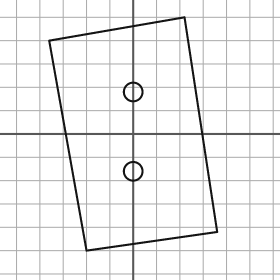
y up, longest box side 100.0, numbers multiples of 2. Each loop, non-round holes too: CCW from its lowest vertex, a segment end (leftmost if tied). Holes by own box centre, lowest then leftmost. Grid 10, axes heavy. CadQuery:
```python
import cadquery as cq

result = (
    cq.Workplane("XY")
    .moveTo(-20.0, -50.0)
    .lineTo(36.0, -42.0)
    .lineTo(22.0, 50.0)
    .lineTo(-36.0, 40.0)
    .close()
    .moveTo(0.0, -16.0)
    .circle(4.0)
    .moveTo(0.0, 18.0)
    .circle(4.0)
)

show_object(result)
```